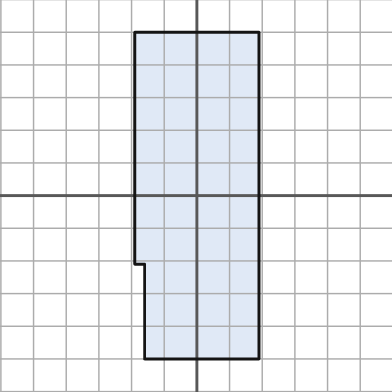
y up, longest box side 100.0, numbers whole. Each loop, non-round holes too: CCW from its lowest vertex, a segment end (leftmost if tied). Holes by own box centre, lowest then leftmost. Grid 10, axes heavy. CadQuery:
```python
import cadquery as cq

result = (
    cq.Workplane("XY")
    .moveTo(-16.0, -50.0)
    .lineTo(19.0, -50.0)
    .lineTo(19.0, 50.0)
    .lineTo(-19.0, 50.0)
    .lineTo(-19.0, -21.0)
    .lineTo(-16.0, -21.0)
    .close()
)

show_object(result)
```